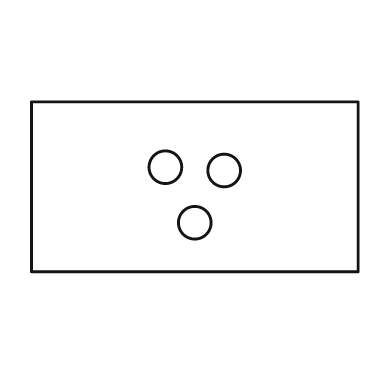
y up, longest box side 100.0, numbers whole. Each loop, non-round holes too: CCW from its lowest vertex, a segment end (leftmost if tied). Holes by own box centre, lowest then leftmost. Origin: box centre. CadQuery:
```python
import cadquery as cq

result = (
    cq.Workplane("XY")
    .moveTo(-50.0, -26.0)
    .lineTo(50.0, -26.0)
    .lineTo(50.0, 26.0)
    .lineTo(-50.0, 26.0)
    .close()
    .moveTo(0.0, -11.0)
    .circle(5.0)
    .moveTo(9.0, 5.0)
    .circle(5.0)
    .moveTo(-9.0, 6.0)
    .circle(5.0)
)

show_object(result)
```